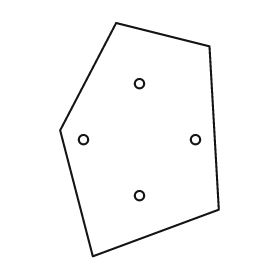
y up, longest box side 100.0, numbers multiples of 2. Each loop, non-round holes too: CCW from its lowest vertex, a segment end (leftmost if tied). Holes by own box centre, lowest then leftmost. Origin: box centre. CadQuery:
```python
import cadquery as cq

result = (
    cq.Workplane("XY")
    .moveTo(-20.0, -50.0)
    .lineTo(34.0, -30.0)
    .lineTo(30.0, 40.0)
    .lineTo(-10.0, 50.0)
    .lineTo(-34.0, 4.0)
    .close()
    .moveTo(0.0, -24.0)
    .circle(2.0)
    .moveTo(-24.0, 0.0)
    .circle(2.0)
    .moveTo(24.0, 0.0)
    .circle(2.0)
    .moveTo(0.0, 24.0)
    .circle(2.0)
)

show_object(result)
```